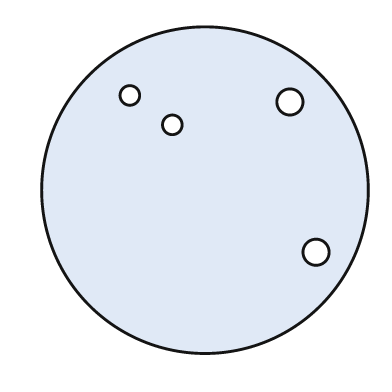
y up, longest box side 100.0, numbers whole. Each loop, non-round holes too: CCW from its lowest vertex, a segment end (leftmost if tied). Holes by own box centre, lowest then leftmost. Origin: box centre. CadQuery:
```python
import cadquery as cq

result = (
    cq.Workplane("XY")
    .moveTo(0.0, 0.0)
    .circle(50.0)
    .moveTo(34.0, -19.0)
    .circle(4.0)
    .moveTo(-10.0, 20.0)
    .circle(3.0)
    .moveTo(26.0, 27.0)
    .circle(4.0)
    .moveTo(-23.0, 29.0)
    .circle(3.0)
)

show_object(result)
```